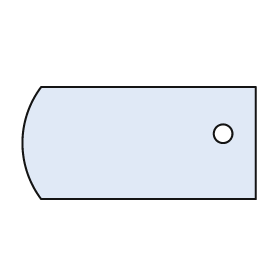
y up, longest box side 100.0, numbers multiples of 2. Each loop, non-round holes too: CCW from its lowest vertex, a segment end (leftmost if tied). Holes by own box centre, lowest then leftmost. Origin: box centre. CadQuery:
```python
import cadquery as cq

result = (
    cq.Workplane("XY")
    .moveTo(-42.0, -24.0)
    .lineTo(50.0, -24.0)
    .lineTo(50.0, 24.0)
    .lineTo(-42.0, 24.0)
    .threePointArc((-50.0, 0.0), (-42.0, -24.0))
    .close()
    .moveTo(36.0, 4.0)
    .circle(4.0)
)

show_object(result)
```